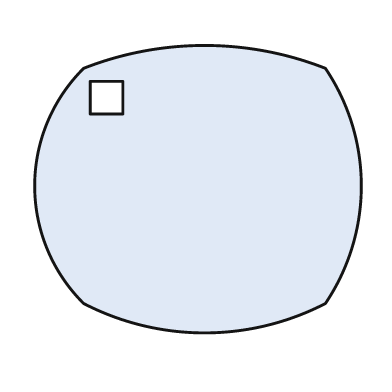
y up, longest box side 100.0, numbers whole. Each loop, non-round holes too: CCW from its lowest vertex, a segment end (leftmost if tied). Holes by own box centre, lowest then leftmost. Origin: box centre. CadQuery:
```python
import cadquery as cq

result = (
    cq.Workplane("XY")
    .moveTo(-35.0, -35.0)
    .threePointArc((2.0, -44.0), (39.0, -35.0))
    .threePointArc((50.0, 1.0), (39.0, 37.0))
    .threePointArc((2.0, 44.0), (-35.0, 37.0))
    .threePointArc((-50.0, 1.0), (-35.0, -35.0))
    .close()
    .moveTo(-33.0, 23.0)
    .lineTo(-23.0, 23.0)
    .lineTo(-23.0, 33.0)
    .lineTo(-33.0, 33.0)
    .close()
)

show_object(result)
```